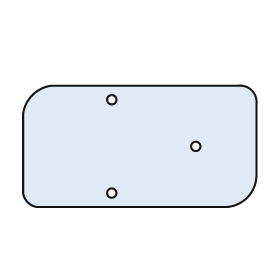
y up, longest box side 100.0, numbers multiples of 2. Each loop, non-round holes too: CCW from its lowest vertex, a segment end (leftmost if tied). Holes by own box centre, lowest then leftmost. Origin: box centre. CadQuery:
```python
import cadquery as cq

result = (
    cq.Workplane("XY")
    .moveTo(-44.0, -26.0)
    .lineTo(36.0, -26.0)
    .threePointArc((46.0, -22.0), (50.0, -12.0))
    .lineTo(50.0, 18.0)
    .threePointArc((48.0, 24.0), (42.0, 26.0))
    .lineTo(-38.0, 26.0)
    .threePointArc((-46.0, 22.0), (-50.0, 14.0))
    .lineTo(-50.0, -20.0)
    .threePointArc((-48.0, -24.0), (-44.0, -26.0))
    .close()
    .moveTo(-12.0, -20.0)
    .circle(2.0)
    .moveTo(24.0, 0.0)
    .circle(2.0)
    .moveTo(-12.0, 20.0)
    .circle(2.0)
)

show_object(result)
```